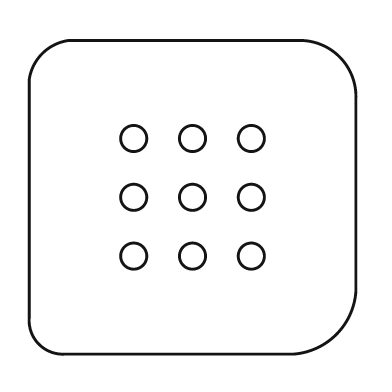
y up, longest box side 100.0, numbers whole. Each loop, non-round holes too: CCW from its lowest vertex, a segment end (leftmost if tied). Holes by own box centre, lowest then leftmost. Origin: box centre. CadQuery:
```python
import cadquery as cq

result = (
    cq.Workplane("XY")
    .moveTo(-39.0, -48.0)
    .lineTo(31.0, -48.0)
    .threePointArc((44.0, -42.0), (50.0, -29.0))
    .lineTo(50.0, 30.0)
    .threePointArc((45.0, 43.0), (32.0, 48.0))
    .lineTo(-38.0, 48.0)
    .threePointArc((-46.0, 44.0), (-50.0, 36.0))
    .lineTo(-50.0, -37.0)
    .threePointArc((-47.0, -45.0), (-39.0, -48.0))
    .close()
    .moveTo(-18.0, -18.0)
    .circle(4.0)
    .moveTo(0.0, -18.0)
    .circle(4.0)
    .moveTo(18.0, -18.0)
    .circle(4.0)
    .moveTo(-18.0, 0.0)
    .circle(4.0)
    .moveTo(0.0, 0.0)
    .circle(4.0)
    .moveTo(18.0, 0.0)
    .circle(4.0)
    .moveTo(-18.0, 18.0)
    .circle(4.0)
    .moveTo(0.0, 18.0)
    .circle(4.0)
    .moveTo(18.0, 18.0)
    .circle(4.0)
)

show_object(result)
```